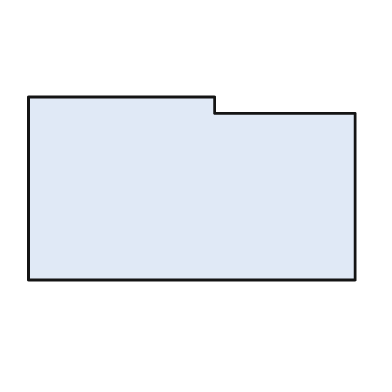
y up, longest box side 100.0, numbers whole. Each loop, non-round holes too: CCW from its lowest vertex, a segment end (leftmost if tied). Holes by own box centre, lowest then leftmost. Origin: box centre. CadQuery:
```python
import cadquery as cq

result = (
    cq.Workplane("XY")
    .moveTo(-50.0, -28.0)
    .lineTo(50.0, -28.0)
    .lineTo(50.0, 23.0)
    .lineTo(7.0, 23.0)
    .lineTo(7.0, 28.0)
    .lineTo(-50.0, 28.0)
    .close()
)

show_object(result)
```